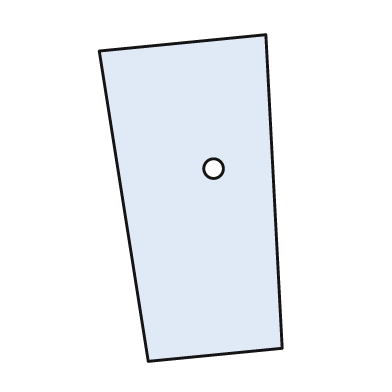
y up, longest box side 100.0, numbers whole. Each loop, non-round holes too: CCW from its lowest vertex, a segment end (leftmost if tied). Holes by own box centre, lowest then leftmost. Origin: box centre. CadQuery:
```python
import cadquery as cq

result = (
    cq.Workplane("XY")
    .moveTo(-13.0, -50.0)
    .lineTo(28.0, -46.0)
    .lineTo(23.0, 50.0)
    .lineTo(-28.0, 45.0)
    .close()
    .moveTo(7.0, 9.0)
    .circle(3.0)
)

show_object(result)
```